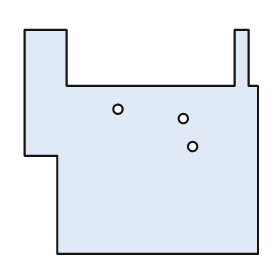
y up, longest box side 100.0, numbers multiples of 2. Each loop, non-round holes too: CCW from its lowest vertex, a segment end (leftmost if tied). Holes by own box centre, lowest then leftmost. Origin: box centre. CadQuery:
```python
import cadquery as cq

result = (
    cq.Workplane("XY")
    .moveTo(-36.0, -48.0)
    .lineTo(50.0, -48.0)
    .lineTo(50.0, 24.0)
    .lineTo(46.0, 24.0)
    .lineTo(46.0, 48.0)
    .lineTo(40.0, 48.0)
    .lineTo(40.0, 24.0)
    .lineTo(-32.0, 24.0)
    .lineTo(-32.0, 48.0)
    .lineTo(-50.0, 48.0)
    .lineTo(-50.0, -6.0)
    .lineTo(-36.0, -6.0)
    .close()
    .moveTo(22.0, -2.0)
    .circle(2.0)
    .moveTo(18.0, 10.0)
    .circle(2.0)
    .moveTo(-10.0, 14.0)
    .circle(2.0)
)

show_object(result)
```